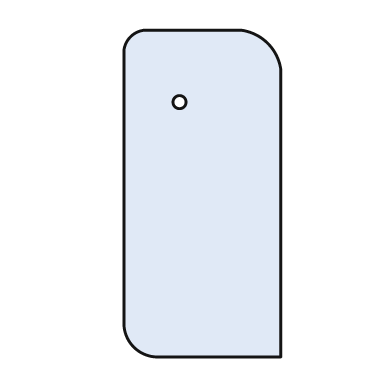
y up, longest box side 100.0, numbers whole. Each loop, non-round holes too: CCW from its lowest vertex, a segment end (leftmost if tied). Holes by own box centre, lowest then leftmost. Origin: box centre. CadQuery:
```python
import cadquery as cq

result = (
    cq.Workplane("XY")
    .moveTo(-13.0, -50.0)
    .lineTo(24.0, -50.0)
    .lineTo(24.0, 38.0)
    .threePointArc((20.0, 46.0), (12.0, 50.0))
    .lineTo(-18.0, 50.0)
    .threePointArc((-22.0, 48.0), (-24.0, 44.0))
    .lineTo(-24.0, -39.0)
    .threePointArc((-21.0, -47.0), (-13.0, -50.0))
    .close()
    .moveTo(-7.0, 28.0)
    .circle(2.0)
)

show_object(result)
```